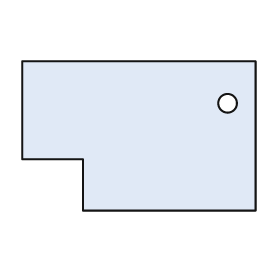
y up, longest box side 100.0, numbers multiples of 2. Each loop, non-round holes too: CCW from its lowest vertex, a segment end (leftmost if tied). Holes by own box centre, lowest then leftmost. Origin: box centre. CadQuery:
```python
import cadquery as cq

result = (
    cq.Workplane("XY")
    .moveTo(-24.0, -32.0)
    .lineTo(50.0, -32.0)
    .lineTo(50.0, 32.0)
    .lineTo(-50.0, 32.0)
    .lineTo(-50.0, -10.0)
    .lineTo(-24.0, -10.0)
    .close()
    .moveTo(38.0, 14.0)
    .circle(4.0)
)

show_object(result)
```